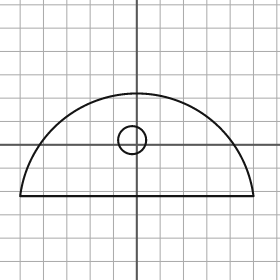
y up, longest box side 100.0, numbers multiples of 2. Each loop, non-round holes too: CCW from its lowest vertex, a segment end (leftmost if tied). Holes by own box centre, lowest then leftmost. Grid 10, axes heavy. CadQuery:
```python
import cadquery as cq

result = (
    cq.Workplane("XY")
    .moveTo(-50.0, -22.0)
    .lineTo(50.0, -22.0)
    .threePointArc((0.0, 22.0), (-50.0, -22.0))
    .close()
    .moveTo(-2.0, 2.0)
    .circle(6.0)
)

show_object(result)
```